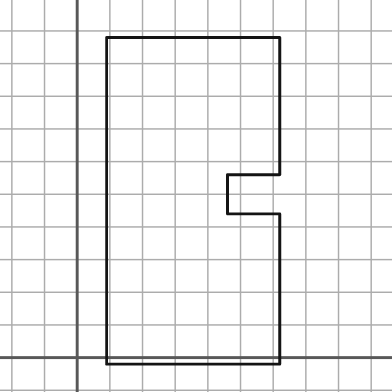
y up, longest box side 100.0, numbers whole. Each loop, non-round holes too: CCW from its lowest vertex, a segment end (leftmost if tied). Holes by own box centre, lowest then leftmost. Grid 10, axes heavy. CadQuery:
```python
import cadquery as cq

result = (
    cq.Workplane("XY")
    .moveTo(9.0, -2.0)
    .lineTo(62.0, -2.0)
    .lineTo(62.0, 44.0)
    .lineTo(46.0, 44.0)
    .lineTo(46.0, 56.0)
    .lineTo(62.0, 56.0)
    .lineTo(62.0, 98.0)
    .lineTo(9.0, 98.0)
    .close()
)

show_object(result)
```